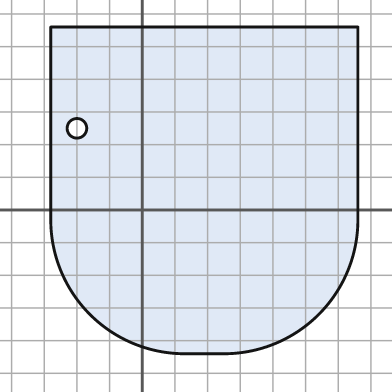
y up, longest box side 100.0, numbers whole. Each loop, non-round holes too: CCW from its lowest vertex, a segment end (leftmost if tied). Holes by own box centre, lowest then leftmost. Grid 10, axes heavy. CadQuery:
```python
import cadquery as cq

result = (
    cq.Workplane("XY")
    .moveTo(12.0, -44.0)
    .lineTo(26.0, -44.0)
    .threePointArc((54.0, -32.0), (66.0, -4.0))
    .lineTo(66.0, 56.0)
    .lineTo(-28.0, 56.0)
    .lineTo(-28.0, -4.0)
    .threePointArc((-16.0, -32.0), (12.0, -44.0))
    .close()
    .moveTo(-20.0, 25.0)
    .circle(3.0)
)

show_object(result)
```